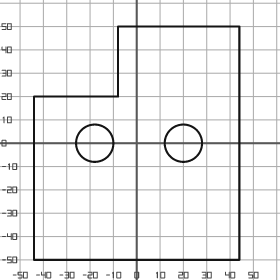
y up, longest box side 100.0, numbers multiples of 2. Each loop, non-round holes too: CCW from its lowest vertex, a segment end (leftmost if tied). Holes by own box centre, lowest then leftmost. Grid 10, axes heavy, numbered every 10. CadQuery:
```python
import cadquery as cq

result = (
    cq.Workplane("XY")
    .moveTo(-44.0, -50.0)
    .lineTo(44.0, -50.0)
    .lineTo(44.0, 50.0)
    .lineTo(-8.0, 50.0)
    .lineTo(-8.0, 20.0)
    .lineTo(-44.0, 20.0)
    .close()
    .moveTo(-18.0, 0.0)
    .circle(8.0)
    .moveTo(20.0, 0.0)
    .circle(8.0)
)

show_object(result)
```